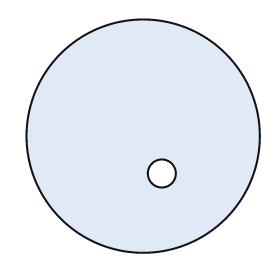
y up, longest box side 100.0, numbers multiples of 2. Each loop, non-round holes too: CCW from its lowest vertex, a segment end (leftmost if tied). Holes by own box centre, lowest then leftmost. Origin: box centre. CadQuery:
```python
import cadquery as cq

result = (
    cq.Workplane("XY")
    .moveTo(0.0, 0.0)
    .circle(50.0)
    .moveTo(8.0, -16.0)
    .circle(6.0)
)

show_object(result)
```